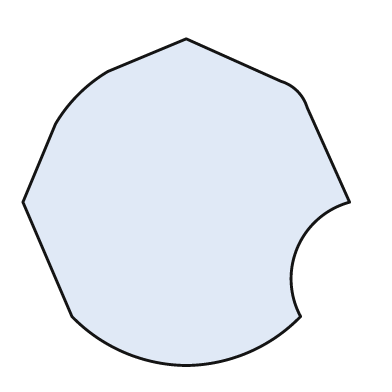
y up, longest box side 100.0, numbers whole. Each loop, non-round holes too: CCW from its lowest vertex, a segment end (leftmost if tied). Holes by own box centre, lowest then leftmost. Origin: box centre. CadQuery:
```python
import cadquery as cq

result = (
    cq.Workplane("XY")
    .moveTo(0.0, -50.0)
    .threePointArc((19.0, -46.0), (35.0, -35.0))
    .threePointArc((34.0, -14.0), (50.0, 0.0))
    .lineTo(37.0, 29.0)
    .threePointArc((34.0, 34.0), (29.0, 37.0))
    .lineTo(0.0, 50.0)
    .lineTo(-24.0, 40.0)
    .threePointArc((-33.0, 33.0), (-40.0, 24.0))
    .lineTo(-50.0, 0.0)
    .lineTo(-35.0, -35.0)
    .threePointArc((-19.0, -46.0), (0.0, -50.0))
    .close()
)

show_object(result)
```